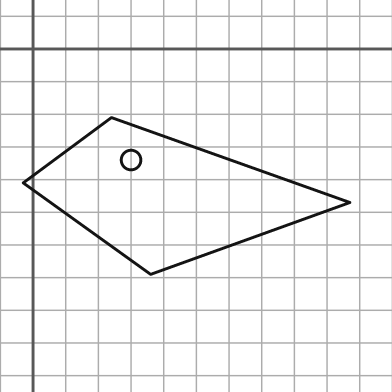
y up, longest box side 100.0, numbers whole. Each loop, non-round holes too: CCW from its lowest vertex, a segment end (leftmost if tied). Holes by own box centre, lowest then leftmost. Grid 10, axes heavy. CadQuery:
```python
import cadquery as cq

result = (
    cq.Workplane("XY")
    .moveTo(36.0, -69.0)
    .lineTo(97.0, -47.0)
    .lineTo(24.0, -21.0)
    .lineTo(-3.0, -41.0)
    .close()
    .moveTo(30.0, -34.0)
    .circle(3.0)
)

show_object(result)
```